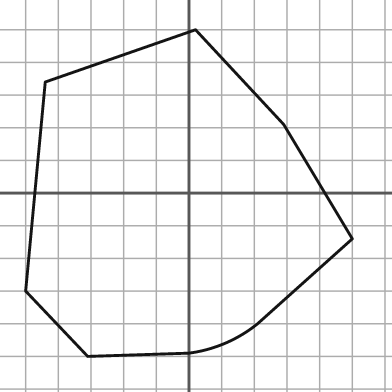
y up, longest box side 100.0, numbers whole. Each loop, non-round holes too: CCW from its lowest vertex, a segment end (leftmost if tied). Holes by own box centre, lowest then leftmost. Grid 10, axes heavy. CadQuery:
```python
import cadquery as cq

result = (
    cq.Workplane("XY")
    .moveTo(-31.0, -50.0)
    .lineTo(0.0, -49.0)
    .threePointArc((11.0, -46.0), (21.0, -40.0))
    .lineTo(50.0, -14.0)
    .lineTo(29.0, 21.0)
    .lineTo(2.0, 50.0)
    .lineTo(-44.0, 34.0)
    .lineTo(-50.0, -30.0)
    .close()
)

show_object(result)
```